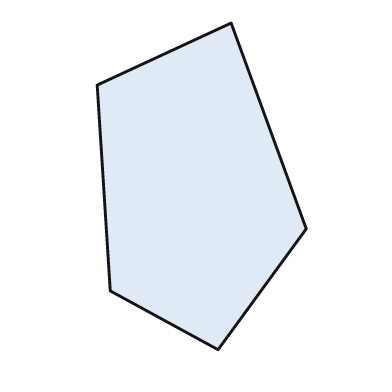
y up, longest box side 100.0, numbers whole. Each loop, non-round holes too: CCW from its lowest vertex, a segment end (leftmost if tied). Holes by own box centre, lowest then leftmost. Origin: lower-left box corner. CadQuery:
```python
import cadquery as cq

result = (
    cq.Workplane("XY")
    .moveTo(37.0, 0.0)
    .lineTo(64.0, 37.0)
    .lineTo(41.0, 100.0)
    .lineTo(0.0, 81.0)
    .lineTo(4.0, 18.0)
    .close()
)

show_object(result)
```